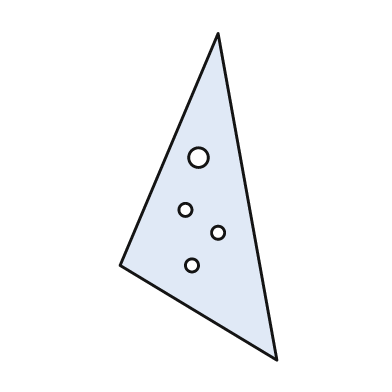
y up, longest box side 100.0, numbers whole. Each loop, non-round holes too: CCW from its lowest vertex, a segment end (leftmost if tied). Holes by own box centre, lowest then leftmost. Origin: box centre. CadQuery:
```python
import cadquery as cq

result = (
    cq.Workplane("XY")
    .moveTo(24.0, -50.0)
    .lineTo(6.0, 50.0)
    .lineTo(-24.0, -21.0)
    .close()
    .moveTo(-2.0, -21.0)
    .circle(2.0)
    .moveTo(6.0, -11.0)
    .circle(2.0)
    .moveTo(-4.0, -4.0)
    .circle(2.0)
    .moveTo(0.0, 12.0)
    .circle(3.0)
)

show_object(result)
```